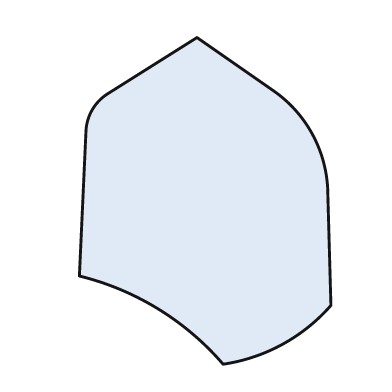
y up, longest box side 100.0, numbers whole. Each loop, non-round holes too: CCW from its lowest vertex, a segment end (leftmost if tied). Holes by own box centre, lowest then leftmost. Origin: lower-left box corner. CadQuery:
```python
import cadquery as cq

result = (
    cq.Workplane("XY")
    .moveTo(44.0, 0.0)
    .threePointArc((62.0, 6.0), (77.0, 18.0))
    .lineTo(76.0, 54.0)
    .threePointArc((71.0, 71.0), (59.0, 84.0))
    .lineTo(36.0, 100.0)
    .lineTo(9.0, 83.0)
    .threePointArc((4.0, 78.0), (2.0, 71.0))
    .lineTo(0.0, 27.0)
    .threePointArc((24.0, 17.0), (44.0, 0.0))
    .close()
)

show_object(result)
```